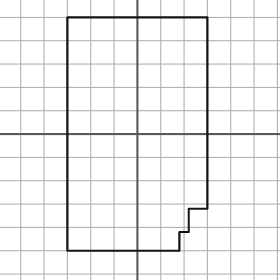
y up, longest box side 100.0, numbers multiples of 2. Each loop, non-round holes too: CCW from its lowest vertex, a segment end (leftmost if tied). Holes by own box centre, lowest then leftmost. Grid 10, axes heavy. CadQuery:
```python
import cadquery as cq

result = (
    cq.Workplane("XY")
    .moveTo(-30.0, -50.0)
    .lineTo(18.0, -50.0)
    .lineTo(18.0, -42.0)
    .lineTo(22.0, -42.0)
    .lineTo(22.0, -32.0)
    .lineTo(30.0, -32.0)
    .lineTo(30.0, 50.0)
    .lineTo(-30.0, 50.0)
    .close()
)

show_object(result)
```